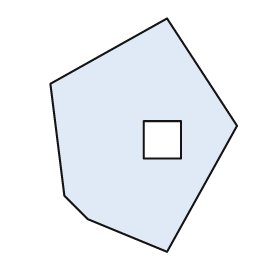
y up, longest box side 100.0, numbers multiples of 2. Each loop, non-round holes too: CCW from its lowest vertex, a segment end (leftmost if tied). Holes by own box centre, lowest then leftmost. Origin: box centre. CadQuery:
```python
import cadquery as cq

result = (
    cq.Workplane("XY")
    .moveTo(10.0, -50.0)
    .lineTo(40.0, 4.0)
    .lineTo(10.0, 50.0)
    .lineTo(-40.0, 22.0)
    .lineTo(-34.0, -26.0)
    .lineTo(-24.0, -36.0)
    .close()
    .moveTo(0.0, -10.0)
    .lineTo(16.0, -10.0)
    .lineTo(16.0, 6.0)
    .lineTo(0.0, 6.0)
    .close()
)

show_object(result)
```